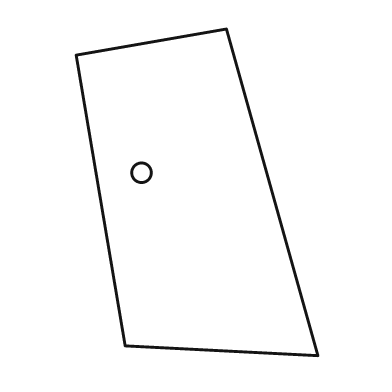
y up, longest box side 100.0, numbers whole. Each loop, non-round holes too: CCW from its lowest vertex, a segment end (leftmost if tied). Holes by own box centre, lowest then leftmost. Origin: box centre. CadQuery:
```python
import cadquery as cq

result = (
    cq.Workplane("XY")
    .moveTo(37.0, -50.0)
    .lineTo(9.0, 50.0)
    .lineTo(-37.0, 42.0)
    .lineTo(-22.0, -47.0)
    .close()
    .moveTo(-17.0, 6.0)
    .circle(3.0)
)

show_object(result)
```